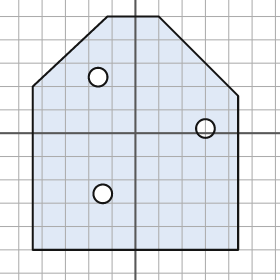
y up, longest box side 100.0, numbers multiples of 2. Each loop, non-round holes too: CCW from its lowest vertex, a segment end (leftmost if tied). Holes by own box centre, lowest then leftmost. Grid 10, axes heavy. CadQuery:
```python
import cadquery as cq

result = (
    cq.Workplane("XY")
    .moveTo(-44.0, -50.0)
    .lineTo(44.0, -50.0)
    .lineTo(44.0, 16.0)
    .lineTo(10.0, 50.0)
    .lineTo(-12.0, 50.0)
    .lineTo(-44.0, 20.0)
    .close()
    .moveTo(-14.0, -26.0)
    .circle(4.0)
    .moveTo(30.0, 2.0)
    .circle(4.0)
    .moveTo(-16.0, 24.0)
    .circle(4.0)
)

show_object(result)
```